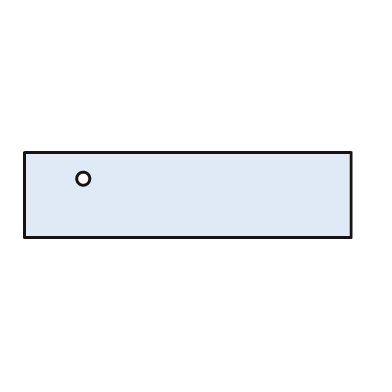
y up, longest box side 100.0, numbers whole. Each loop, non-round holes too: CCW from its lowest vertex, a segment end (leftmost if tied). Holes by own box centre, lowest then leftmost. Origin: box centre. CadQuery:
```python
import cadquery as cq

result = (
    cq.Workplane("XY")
    .moveTo(-50.0, -13.0)
    .lineTo(50.0, -13.0)
    .lineTo(50.0, 13.0)
    .lineTo(-50.0, 13.0)
    .close()
    .moveTo(-32.0, 5.0)
    .circle(2.0)
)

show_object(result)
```